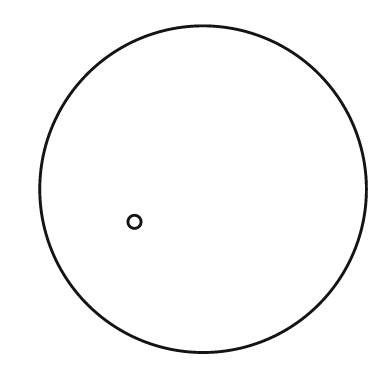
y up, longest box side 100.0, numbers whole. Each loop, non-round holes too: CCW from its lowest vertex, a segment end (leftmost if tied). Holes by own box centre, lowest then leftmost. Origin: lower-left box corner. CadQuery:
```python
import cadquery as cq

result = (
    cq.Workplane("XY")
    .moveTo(50.0, 50.0)
    .circle(50.0)
    .moveTo(29.0, 40.0)
    .circle(2.0)
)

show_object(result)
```